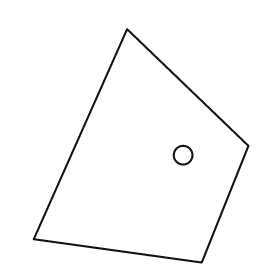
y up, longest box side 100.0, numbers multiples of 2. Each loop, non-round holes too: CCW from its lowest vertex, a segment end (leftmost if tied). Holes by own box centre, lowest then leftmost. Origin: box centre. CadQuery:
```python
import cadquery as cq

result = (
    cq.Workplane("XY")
    .moveTo(26.0, -50.0)
    .lineTo(46.0, 0.0)
    .lineTo(-6.0, 50.0)
    .lineTo(-46.0, -40.0)
    .close()
    .moveTo(18.0, -4.0)
    .circle(4.0)
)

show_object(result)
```